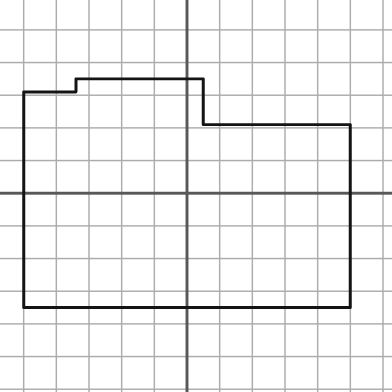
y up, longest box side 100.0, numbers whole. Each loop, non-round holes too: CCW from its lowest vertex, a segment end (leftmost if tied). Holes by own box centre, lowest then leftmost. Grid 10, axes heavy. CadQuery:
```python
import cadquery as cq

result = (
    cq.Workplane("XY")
    .moveTo(-50.0, -35.0)
    .lineTo(50.0, -35.0)
    .lineTo(50.0, 21.0)
    .lineTo(5.0, 21.0)
    .lineTo(5.0, 35.0)
    .lineTo(-34.0, 35.0)
    .lineTo(-34.0, 31.0)
    .lineTo(-50.0, 31.0)
    .close()
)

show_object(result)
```